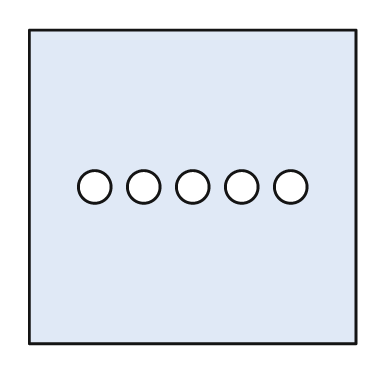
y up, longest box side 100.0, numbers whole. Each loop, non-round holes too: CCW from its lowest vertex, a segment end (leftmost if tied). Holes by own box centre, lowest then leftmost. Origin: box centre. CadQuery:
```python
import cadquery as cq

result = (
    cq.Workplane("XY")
    .moveTo(-50.0, -48.0)
    .lineTo(50.0, -48.0)
    .lineTo(50.0, 48.0)
    .lineTo(-50.0, 48.0)
    .close()
    .moveTo(-30.0, 0.0)
    .circle(5.0)
    .moveTo(-15.0, 0.0)
    .circle(5.0)
    .moveTo(0.0, 0.0)
    .circle(5.0)
    .moveTo(15.0, 0.0)
    .circle(5.0)
    .moveTo(30.0, 0.0)
    .circle(5.0)
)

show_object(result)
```